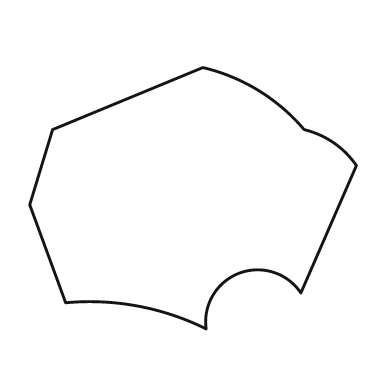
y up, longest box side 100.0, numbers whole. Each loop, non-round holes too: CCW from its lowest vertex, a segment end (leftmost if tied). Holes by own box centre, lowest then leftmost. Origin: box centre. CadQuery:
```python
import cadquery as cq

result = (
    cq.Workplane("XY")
    .moveTo(4.0, -40.0)
    .threePointArc((14.0, -23.0), (33.0, -29.0))
    .lineTo(50.0, 10.0)
    .threePointArc((43.0, 17.0), (34.0, 21.0))
    .threePointArc((20.0, 33.0), (3.0, 40.0))
    .lineTo(-43.0, 21.0)
    .lineTo(-50.0, -2.0)
    .lineTo(-39.0, -32.0)
    .threePointArc((-17.0, -33.0), (4.0, -40.0))
    .close()
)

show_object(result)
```